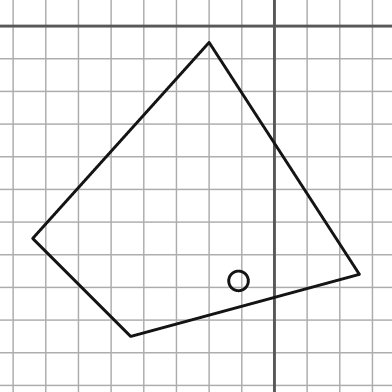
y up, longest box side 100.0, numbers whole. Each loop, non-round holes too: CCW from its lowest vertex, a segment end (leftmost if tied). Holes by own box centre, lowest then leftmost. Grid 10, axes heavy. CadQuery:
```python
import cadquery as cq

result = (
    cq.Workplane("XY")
    .moveTo(-44.0, -95.0)
    .lineTo(26.0, -76.0)
    .lineTo(-20.0, -5.0)
    .lineTo(-74.0, -65.0)
    .close()
    .moveTo(-11.0, -78.0)
    .circle(3.0)
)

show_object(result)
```